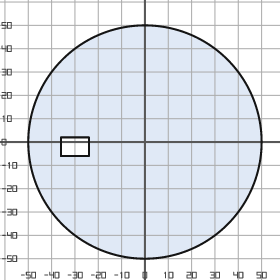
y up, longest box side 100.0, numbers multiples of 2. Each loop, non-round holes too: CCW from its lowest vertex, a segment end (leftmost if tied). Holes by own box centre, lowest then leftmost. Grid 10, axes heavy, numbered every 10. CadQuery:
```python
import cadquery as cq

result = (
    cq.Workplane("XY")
    .moveTo(0.0, 0.0)
    .circle(50.0)
    .moveTo(-36.0, -6.0)
    .lineTo(-24.0, -6.0)
    .lineTo(-24.0, 2.0)
    .lineTo(-36.0, 2.0)
    .close()
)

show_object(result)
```